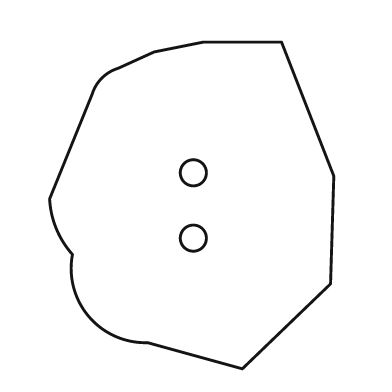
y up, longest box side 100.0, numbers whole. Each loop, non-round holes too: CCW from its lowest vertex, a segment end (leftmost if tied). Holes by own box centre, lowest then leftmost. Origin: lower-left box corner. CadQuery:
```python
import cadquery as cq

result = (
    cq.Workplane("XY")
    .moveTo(59.0, 0.0)
    .lineTo(86.0, 26.0)
    .lineTo(87.0, 59.0)
    .lineTo(71.0, 100.0)
    .lineTo(47.0, 100.0)
    .lineTo(32.0, 97.0)
    .lineTo(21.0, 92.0)
    .threePointArc((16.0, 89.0), (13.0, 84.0))
    .lineTo(0.0, 52.0)
    .threePointArc((2.0, 43.0), (7.0, 35.0))
    .threePointArc((12.0, 16.0), (30.0, 8.0))
    .close()
    .moveTo(44.0, 40.0)
    .circle(4.0)
    .moveTo(44.0, 60.0)
    .circle(4.0)
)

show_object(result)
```